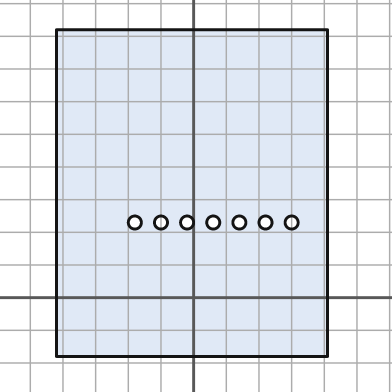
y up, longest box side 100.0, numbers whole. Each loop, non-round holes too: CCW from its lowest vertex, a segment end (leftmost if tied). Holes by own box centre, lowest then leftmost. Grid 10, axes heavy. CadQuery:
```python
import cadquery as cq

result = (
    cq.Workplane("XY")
    .moveTo(-42.0, -18.0)
    .lineTo(41.0, -18.0)
    .lineTo(41.0, 82.0)
    .lineTo(-42.0, 82.0)
    .close()
    .moveTo(-18.0, 23.0)
    .circle(2.0)
    .moveTo(-10.0, 23.0)
    .circle(2.0)
    .moveTo(-2.0, 23.0)
    .circle(2.0)
    .moveTo(6.0, 23.0)
    .circle(2.0)
    .moveTo(14.0, 23.0)
    .circle(2.0)
    .moveTo(22.0, 23.0)
    .circle(2.0)
    .moveTo(30.0, 23.0)
    .circle(2.0)
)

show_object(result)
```